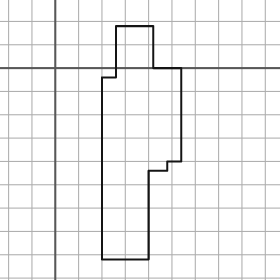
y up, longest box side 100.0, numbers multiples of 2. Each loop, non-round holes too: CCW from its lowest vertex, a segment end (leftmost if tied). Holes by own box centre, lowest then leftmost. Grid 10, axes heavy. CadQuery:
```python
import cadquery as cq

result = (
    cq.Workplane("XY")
    .moveTo(20.0, -82.0)
    .lineTo(40.0, -82.0)
    .lineTo(40.0, -44.0)
    .lineTo(48.0, -44.0)
    .lineTo(48.0, -40.0)
    .lineTo(54.0, -40.0)
    .lineTo(54.0, 0.0)
    .lineTo(42.0, 0.0)
    .lineTo(42.0, 18.0)
    .lineTo(26.0, 18.0)
    .lineTo(26.0, -4.0)
    .lineTo(20.0, -4.0)
    .close()
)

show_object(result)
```